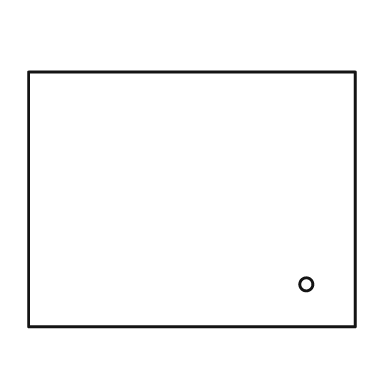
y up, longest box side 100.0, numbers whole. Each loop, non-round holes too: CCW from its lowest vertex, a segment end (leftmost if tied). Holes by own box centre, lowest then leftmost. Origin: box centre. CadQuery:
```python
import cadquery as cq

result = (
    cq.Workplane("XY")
    .moveTo(-50.0, -39.0)
    .lineTo(50.0, -39.0)
    .lineTo(50.0, 39.0)
    .lineTo(-50.0, 39.0)
    .close()
    .moveTo(35.0, -26.0)
    .circle(2.0)
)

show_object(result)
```